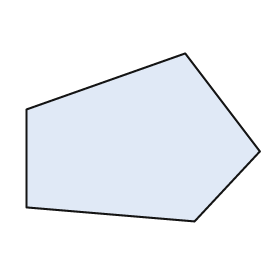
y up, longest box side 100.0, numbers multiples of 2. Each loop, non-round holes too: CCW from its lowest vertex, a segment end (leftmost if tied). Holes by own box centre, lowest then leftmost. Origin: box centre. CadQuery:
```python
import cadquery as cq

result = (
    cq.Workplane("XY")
    .moveTo(22.0, -36.0)
    .lineTo(50.0, -6.0)
    .lineTo(18.0, 36.0)
    .lineTo(-50.0, 12.0)
    .lineTo(-50.0, -30.0)
    .close()
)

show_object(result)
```